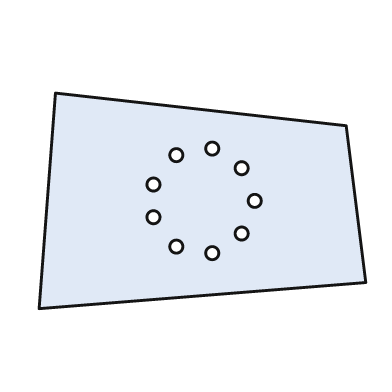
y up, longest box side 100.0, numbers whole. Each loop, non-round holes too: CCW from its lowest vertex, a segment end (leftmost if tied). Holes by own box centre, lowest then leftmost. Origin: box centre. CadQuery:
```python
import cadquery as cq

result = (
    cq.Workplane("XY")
    .moveTo(-50.0, -33.0)
    .lineTo(50.0, -25.0)
    .lineTo(44.0, 23.0)
    .lineTo(-45.0, 33.0)
    .close()
    .moveTo(3.0, -16.0)
    .circle(2.0)
    .moveTo(-8.0, -14.0)
    .circle(2.0)
    .moveTo(12.0, -10.0)
    .circle(2.0)
    .moveTo(-15.0, -5.0)
    .circle(2.0)
    .moveTo(16.0, 0.0)
    .circle(2.0)
    .moveTo(-15.0, 5.0)
    .circle(2.0)
    .moveTo(12.0, 10.0)
    .circle(2.0)
    .moveTo(-8.0, 14.0)
    .circle(2.0)
    .moveTo(3.0, 16.0)
    .circle(2.0)
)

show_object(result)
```